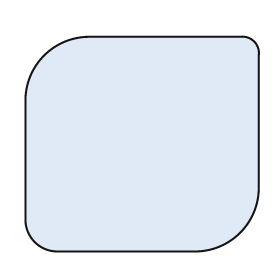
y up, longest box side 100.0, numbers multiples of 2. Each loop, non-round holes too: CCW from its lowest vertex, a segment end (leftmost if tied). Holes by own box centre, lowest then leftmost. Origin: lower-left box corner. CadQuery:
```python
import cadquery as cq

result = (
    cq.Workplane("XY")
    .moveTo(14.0, 0.0)
    .lineTo(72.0, 0.0)
    .threePointArc((92.0, 8.0), (100.0, 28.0))
    .lineTo(100.0, 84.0)
    .threePointArc((98.0, 90.0), (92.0, 92.0))
    .lineTo(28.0, 92.0)
    .threePointArc((8.0, 84.0), (0.0, 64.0))
    .lineTo(0.0, 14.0)
    .threePointArc((4.0, 4.0), (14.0, 0.0))
    .close()
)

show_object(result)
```